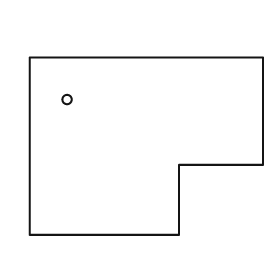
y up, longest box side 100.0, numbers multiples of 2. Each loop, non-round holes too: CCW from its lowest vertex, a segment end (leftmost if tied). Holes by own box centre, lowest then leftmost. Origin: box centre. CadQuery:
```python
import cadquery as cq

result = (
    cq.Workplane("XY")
    .moveTo(-50.0, -38.0)
    .lineTo(14.0, -38.0)
    .lineTo(14.0, -8.0)
    .lineTo(50.0, -8.0)
    .lineTo(50.0, 38.0)
    .lineTo(-50.0, 38.0)
    .close()
    .moveTo(-34.0, 20.0)
    .circle(2.0)
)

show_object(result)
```